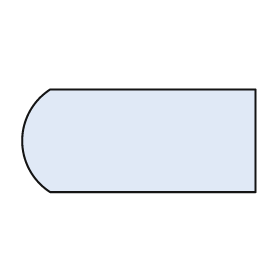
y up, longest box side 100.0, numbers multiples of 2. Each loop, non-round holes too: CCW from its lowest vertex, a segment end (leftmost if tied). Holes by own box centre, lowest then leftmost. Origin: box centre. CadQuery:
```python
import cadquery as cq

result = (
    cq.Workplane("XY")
    .moveTo(-38.0, -22.0)
    .lineTo(50.0, -22.0)
    .lineTo(50.0, 22.0)
    .lineTo(-38.0, 22.0)
    .threePointArc((-50.0, 0.0), (-38.0, -22.0))
    .close()
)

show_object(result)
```